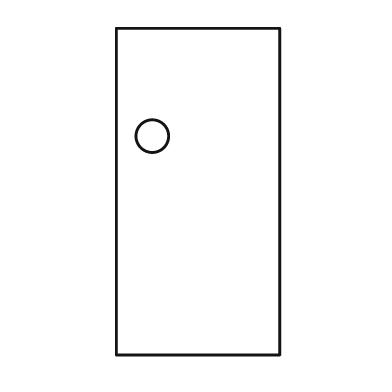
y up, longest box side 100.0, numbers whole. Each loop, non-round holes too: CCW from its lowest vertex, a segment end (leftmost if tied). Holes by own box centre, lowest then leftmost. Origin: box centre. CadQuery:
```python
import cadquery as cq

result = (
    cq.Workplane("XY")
    .moveTo(-25.0, -50.0)
    .lineTo(25.0, -50.0)
    .lineTo(25.0, 50.0)
    .lineTo(-25.0, 50.0)
    .close()
    .moveTo(-14.0, 17.0)
    .circle(5.0)
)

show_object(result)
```